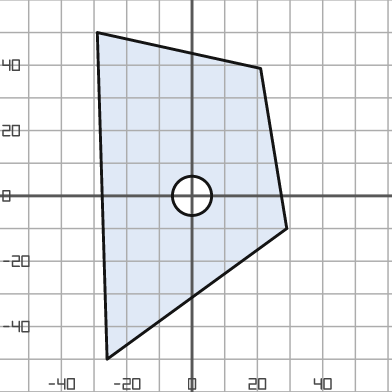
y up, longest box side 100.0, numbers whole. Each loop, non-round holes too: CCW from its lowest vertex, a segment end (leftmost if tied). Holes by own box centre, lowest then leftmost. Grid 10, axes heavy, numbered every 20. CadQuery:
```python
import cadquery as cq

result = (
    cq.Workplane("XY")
    .moveTo(-26.0, -50.0)
    .lineTo(29.0, -10.0)
    .lineTo(21.0, 39.0)
    .lineTo(-29.0, 50.0)
    .close()
    .moveTo(0.0, 0.0)
    .circle(6.0)
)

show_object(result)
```